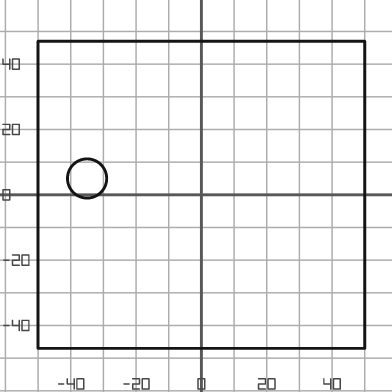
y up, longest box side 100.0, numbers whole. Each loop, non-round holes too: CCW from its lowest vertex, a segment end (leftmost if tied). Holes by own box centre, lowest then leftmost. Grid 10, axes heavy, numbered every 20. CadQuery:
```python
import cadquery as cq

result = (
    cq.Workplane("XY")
    .moveTo(-50.0, -47.0)
    .lineTo(50.0, -47.0)
    .lineTo(50.0, 47.0)
    .lineTo(-50.0, 47.0)
    .close()
    .moveTo(-35.0, 5.0)
    .circle(6.0)
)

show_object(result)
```